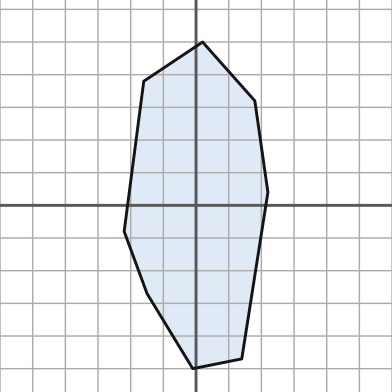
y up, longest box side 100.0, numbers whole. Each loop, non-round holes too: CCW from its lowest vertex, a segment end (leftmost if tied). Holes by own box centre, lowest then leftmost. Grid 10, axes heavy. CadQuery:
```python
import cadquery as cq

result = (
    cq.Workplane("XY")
    .moveTo(-1.0, -50.0)
    .lineTo(14.0, -47.0)
    .lineTo(22.0, 4.0)
    .lineTo(18.0, 32.0)
    .lineTo(2.0, 50.0)
    .lineTo(-16.0, 38.0)
    .lineTo(-22.0, -8.0)
    .lineTo(-15.0, -27.0)
    .close()
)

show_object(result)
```